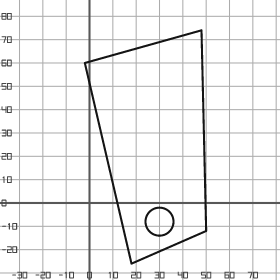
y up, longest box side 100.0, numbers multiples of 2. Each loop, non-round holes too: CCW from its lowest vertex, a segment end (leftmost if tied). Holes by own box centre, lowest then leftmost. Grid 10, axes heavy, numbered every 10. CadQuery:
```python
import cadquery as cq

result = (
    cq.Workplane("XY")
    .moveTo(18.0, -26.0)
    .lineTo(50.0, -12.0)
    .lineTo(48.0, 74.0)
    .lineTo(-2.0, 60.0)
    .close()
    .moveTo(30.0, -8.0)
    .circle(6.0)
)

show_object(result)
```